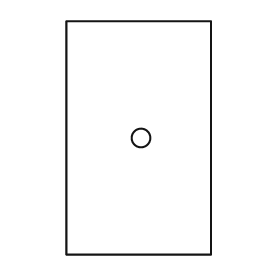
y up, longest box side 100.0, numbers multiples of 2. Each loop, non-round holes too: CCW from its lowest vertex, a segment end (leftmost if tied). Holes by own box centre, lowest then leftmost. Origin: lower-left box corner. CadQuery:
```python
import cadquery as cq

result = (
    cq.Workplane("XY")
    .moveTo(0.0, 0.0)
    .lineTo(62.0, 0.0)
    .lineTo(62.0, 100.0)
    .lineTo(0.0, 100.0)
    .close()
    .moveTo(32.0, 50.0)
    .circle(4.0)
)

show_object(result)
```